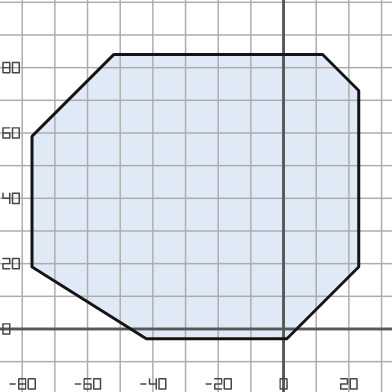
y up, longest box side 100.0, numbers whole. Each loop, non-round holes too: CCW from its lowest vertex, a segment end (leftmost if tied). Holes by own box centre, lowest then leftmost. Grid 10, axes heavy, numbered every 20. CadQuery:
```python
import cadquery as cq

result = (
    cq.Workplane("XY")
    .moveTo(-42.0, -3.0)
    .lineTo(1.0, -3.0)
    .lineTo(23.0, 19.0)
    .lineTo(23.0, 73.0)
    .lineTo(12.0, 84.0)
    .lineTo(-52.0, 84.0)
    .lineTo(-77.0, 59.0)
    .lineTo(-77.0, 19.0)
    .close()
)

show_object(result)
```